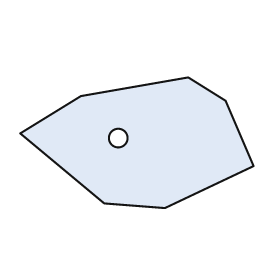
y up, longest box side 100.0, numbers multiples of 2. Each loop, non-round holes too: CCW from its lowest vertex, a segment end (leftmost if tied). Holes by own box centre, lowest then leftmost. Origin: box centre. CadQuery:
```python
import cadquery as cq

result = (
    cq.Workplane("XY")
    .moveTo(12.0, -28.0)
    .lineTo(50.0, -10.0)
    .lineTo(38.0, 18.0)
    .lineTo(22.0, 28.0)
    .lineTo(-24.0, 20.0)
    .lineTo(-50.0, 4.0)
    .lineTo(-14.0, -26.0)
    .close()
    .moveTo(-8.0, 2.0)
    .circle(4.0)
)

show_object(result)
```